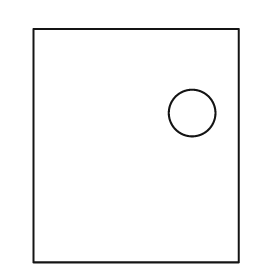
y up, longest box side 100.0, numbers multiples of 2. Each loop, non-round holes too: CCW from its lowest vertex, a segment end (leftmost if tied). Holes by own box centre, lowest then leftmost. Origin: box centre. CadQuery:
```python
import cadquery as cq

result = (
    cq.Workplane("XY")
    .moveTo(-44.0, -50.0)
    .lineTo(44.0, -50.0)
    .lineTo(44.0, 50.0)
    .lineTo(-44.0, 50.0)
    .close()
    .moveTo(24.0, 14.0)
    .circle(10.0)
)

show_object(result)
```